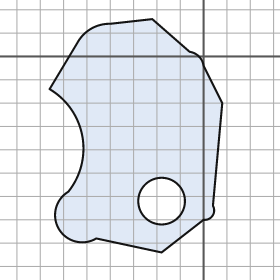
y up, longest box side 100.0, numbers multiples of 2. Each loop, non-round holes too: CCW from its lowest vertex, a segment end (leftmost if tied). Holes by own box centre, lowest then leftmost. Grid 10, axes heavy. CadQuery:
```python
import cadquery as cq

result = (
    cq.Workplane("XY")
    .moveTo(-18.0, -84.0)
    .lineTo(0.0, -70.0)
    .threePointArc((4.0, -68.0), (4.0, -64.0))
    .lineTo(8.0, -20.0)
    .lineTo(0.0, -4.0)
    .threePointArc((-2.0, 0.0), (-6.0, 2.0))
    .lineTo(-22.0, 16.0)
    .lineTo(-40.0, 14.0)
    .threePointArc((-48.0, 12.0), (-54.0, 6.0))
    .lineTo(-66.0, -14.0)
    .threePointArc((-52.0, -34.0), (-58.0, -58.0))
    .threePointArc((-62.0, -74.0), (-46.0, -78.0))
    .close()
    .moveTo(-18.0, -62.0)
    .circle(10.0)
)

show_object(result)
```